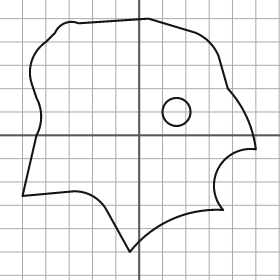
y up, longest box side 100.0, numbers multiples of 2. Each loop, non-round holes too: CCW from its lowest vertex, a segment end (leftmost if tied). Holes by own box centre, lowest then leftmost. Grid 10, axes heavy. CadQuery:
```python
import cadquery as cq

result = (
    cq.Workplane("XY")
    .moveTo(-4.0, -50.0)
    .threePointArc((14.0, -36.0), (36.0, -32.0))
    .threePointArc((34.0, -14.0), (50.0, -6.0))
    .threePointArc((46.0, 8.0), (38.0, 20.0))
    .lineTo(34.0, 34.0)
    .threePointArc((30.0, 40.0), (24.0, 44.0))
    .lineTo(4.0, 50.0)
    .lineTo(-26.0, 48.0)
    .threePointArc((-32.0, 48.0), (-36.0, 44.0))
    .lineTo(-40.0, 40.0)
    .threePointArc((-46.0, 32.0), (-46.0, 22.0))
    .lineTo(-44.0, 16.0)
    .threePointArc((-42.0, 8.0), (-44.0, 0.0))
    .lineTo(-50.0, -26.0)
    .lineTo(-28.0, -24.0)
    .threePointArc((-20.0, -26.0), (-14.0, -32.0))
    .close()
    .moveTo(16.0, 10.0)
    .circle(6.0)
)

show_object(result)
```